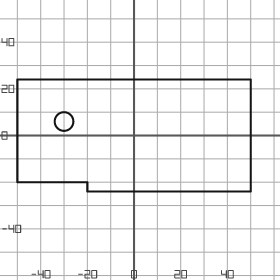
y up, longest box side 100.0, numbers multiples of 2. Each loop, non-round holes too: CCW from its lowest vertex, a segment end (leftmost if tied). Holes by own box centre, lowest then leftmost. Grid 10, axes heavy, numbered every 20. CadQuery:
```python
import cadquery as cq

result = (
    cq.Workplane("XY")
    .moveTo(-20.0, -24.0)
    .lineTo(50.0, -24.0)
    .lineTo(50.0, 24.0)
    .lineTo(-50.0, 24.0)
    .lineTo(-50.0, -20.0)
    .lineTo(-20.0, -20.0)
    .close()
    .moveTo(-30.0, 6.0)
    .circle(4.0)
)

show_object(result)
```